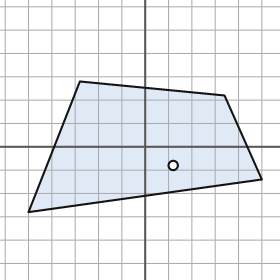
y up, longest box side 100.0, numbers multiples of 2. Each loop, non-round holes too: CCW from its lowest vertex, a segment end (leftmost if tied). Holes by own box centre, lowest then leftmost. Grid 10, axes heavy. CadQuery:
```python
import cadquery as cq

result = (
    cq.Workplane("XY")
    .moveTo(-50.0, -28.0)
    .lineTo(50.0, -14.0)
    .lineTo(34.0, 22.0)
    .lineTo(-28.0, 28.0)
    .close()
    .moveTo(12.0, -8.0)
    .circle(2.0)
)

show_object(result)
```